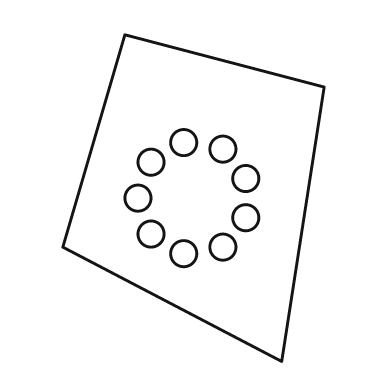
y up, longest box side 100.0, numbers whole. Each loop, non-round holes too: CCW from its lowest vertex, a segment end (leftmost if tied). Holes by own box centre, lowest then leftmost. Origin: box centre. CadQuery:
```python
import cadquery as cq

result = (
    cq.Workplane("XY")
    .moveTo(27.0, -50.0)
    .lineTo(40.0, 34.0)
    .lineTo(-21.0, 50.0)
    .lineTo(-40.0, -15.0)
    .close()
    .moveTo(-3.0, -17.0)
    .circle(4.0)
    .moveTo(9.0, -15.0)
    .circle(4.0)
    .moveTo(-13.0, -11.0)
    .circle(4.0)
    .moveTo(16.0, -6.0)
    .circle(4.0)
    .moveTo(-17.0, 0.0)
    .circle(4.0)
    .moveTo(16.0, 6.0)
    .circle(4.0)
    .moveTo(-13.0, 11.0)
    .circle(4.0)
    .moveTo(9.0, 15.0)
    .circle(4.0)
    .moveTo(-3.0, 17.0)
    .circle(4.0)
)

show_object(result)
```